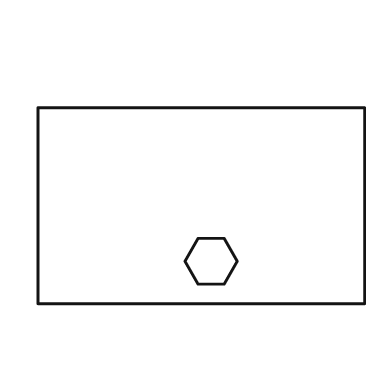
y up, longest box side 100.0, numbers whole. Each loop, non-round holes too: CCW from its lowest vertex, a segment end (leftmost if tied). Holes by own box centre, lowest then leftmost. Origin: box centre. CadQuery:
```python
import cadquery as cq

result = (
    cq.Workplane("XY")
    .moveTo(-50.0, -30.0)
    .lineTo(50.0, -30.0)
    .lineTo(50.0, 30.0)
    .lineTo(-50.0, 30.0)
    .close()
    .moveTo(-1.0, -24.0)
    .lineTo(7.0, -24.0)
    .lineTo(11.0, -17.0)
    .lineTo(7.0, -10.0)
    .lineTo(-1.0, -10.0)
    .lineTo(-5.0, -17.0)
    .close()
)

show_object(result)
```